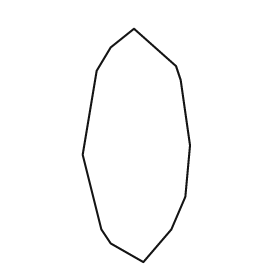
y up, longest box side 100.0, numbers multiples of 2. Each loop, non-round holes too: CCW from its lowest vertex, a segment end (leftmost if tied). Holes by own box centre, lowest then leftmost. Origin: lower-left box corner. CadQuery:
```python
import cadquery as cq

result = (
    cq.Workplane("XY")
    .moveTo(26.0, 0.0)
    .lineTo(38.0, 14.0)
    .lineTo(44.0, 28.0)
    .lineTo(46.0, 50.0)
    .lineTo(42.0, 78.0)
    .lineTo(40.0, 84.0)
    .lineTo(22.0, 100.0)
    .lineTo(12.0, 92.0)
    .lineTo(6.0, 82.0)
    .lineTo(0.0, 46.0)
    .lineTo(8.0, 14.0)
    .lineTo(12.0, 8.0)
    .close()
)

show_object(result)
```